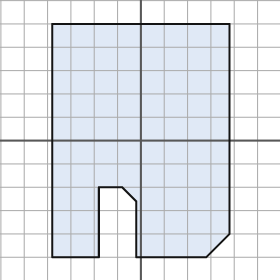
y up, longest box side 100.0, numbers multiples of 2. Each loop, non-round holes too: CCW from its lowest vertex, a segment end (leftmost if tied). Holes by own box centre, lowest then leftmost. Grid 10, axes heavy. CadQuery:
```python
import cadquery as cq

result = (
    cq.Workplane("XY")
    .moveTo(-38.0, -50.0)
    .lineTo(-18.0, -50.0)
    .lineTo(-18.0, -20.0)
    .lineTo(-8.0, -20.0)
    .lineTo(-2.0, -26.0)
    .lineTo(-2.0, -50.0)
    .lineTo(28.0, -50.0)
    .lineTo(38.0, -40.0)
    .lineTo(38.0, 50.0)
    .lineTo(-38.0, 50.0)
    .close()
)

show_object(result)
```